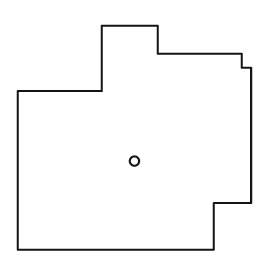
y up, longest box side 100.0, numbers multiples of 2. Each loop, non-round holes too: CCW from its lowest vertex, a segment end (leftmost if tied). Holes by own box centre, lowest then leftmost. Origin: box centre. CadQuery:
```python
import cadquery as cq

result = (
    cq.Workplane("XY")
    .moveTo(-50.0, -48.0)
    .lineTo(34.0, -48.0)
    .lineTo(34.0, -28.0)
    .lineTo(50.0, -28.0)
    .lineTo(50.0, 30.0)
    .lineTo(46.0, 30.0)
    .lineTo(46.0, 36.0)
    .lineTo(10.0, 36.0)
    .lineTo(10.0, 48.0)
    .lineTo(-14.0, 48.0)
    .lineTo(-14.0, 20.0)
    .lineTo(-50.0, 20.0)
    .close()
    .moveTo(0.0, -10.0)
    .circle(2.0)
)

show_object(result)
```